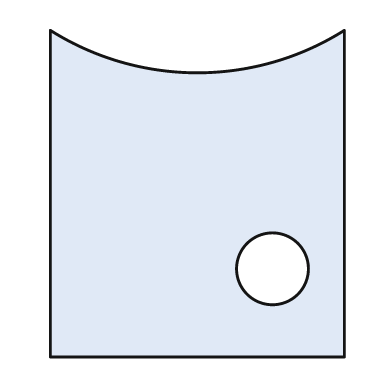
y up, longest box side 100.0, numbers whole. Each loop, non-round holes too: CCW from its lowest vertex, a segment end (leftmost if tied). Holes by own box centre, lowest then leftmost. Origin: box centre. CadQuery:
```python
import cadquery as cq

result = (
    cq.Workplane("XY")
    .moveTo(-45.0, -50.0)
    .lineTo(45.0, -50.0)
    .lineTo(45.0, 50.0)
    .threePointArc((0.0, 37.0), (-45.0, 50.0))
    .close()
    .moveTo(23.0, -23.0)
    .circle(11.0)
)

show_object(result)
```